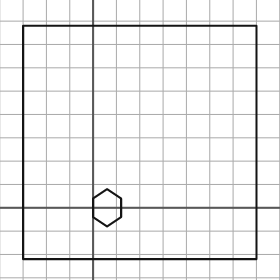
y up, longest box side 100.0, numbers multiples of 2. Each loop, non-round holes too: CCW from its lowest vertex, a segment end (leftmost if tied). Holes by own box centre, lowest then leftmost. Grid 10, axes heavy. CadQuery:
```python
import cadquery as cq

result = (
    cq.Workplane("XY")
    .moveTo(-30.0, -22.0)
    .lineTo(70.0, -22.0)
    .lineTo(70.0, 78.0)
    .lineTo(-30.0, 78.0)
    .close()
    .moveTo(6.0, -8.0)
    .lineTo(12.0, -4.0)
    .lineTo(12.0, 4.0)
    .lineTo(6.0, 8.0)
    .lineTo(0.0, 4.0)
    .lineTo(0.0, -4.0)
    .close()
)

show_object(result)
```